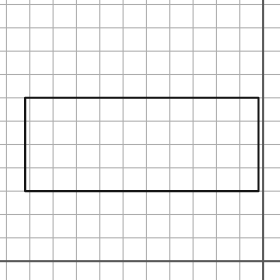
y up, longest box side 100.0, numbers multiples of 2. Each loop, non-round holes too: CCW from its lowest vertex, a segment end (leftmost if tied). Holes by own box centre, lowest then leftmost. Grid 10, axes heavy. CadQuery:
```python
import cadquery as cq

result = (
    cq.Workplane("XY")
    .moveTo(-102.0, 30.0)
    .lineTo(-2.0, 30.0)
    .lineTo(-2.0, 70.0)
    .lineTo(-102.0, 70.0)
    .close()
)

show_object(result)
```